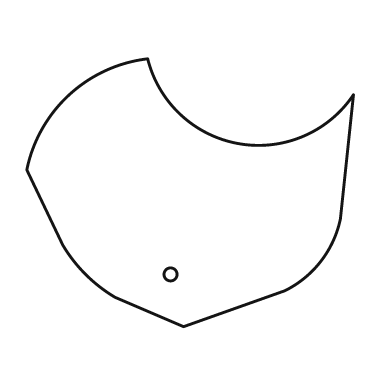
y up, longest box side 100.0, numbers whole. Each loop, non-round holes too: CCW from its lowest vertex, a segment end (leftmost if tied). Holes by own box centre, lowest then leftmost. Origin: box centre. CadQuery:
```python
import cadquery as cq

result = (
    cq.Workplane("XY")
    .moveTo(-2.0, -41.0)
    .lineTo(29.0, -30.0)
    .threePointArc((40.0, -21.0), (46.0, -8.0))
    .lineTo(50.0, 30.0)
    .threePointArc((15.0, 15.0), (-13.0, 41.0))
    .threePointArc((-37.0, 30.0), (-50.0, 7.0))
    .lineTo(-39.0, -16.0)
    .threePointArc((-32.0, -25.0), (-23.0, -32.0))
    .close()
    .moveTo(-6.0, -25.0)
    .circle(2.0)
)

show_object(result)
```